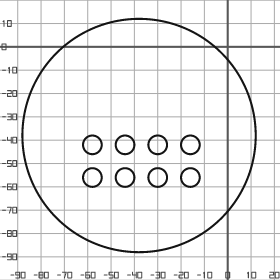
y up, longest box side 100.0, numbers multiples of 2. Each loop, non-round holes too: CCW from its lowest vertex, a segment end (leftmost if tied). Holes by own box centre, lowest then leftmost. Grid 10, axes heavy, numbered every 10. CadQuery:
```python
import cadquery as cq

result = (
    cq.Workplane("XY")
    .moveTo(-38.0, -38.0)
    .circle(50.0)
    .moveTo(-58.0, -56.0)
    .circle(4.0)
    .moveTo(-44.0, -56.0)
    .circle(4.0)
    .moveTo(-30.0, -56.0)
    .circle(4.0)
    .moveTo(-16.0, -56.0)
    .circle(4.0)
    .moveTo(-58.0, -42.0)
    .circle(4.0)
    .moveTo(-44.0, -42.0)
    .circle(4.0)
    .moveTo(-30.0, -42.0)
    .circle(4.0)
    .moveTo(-16.0, -42.0)
    .circle(4.0)
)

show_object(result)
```